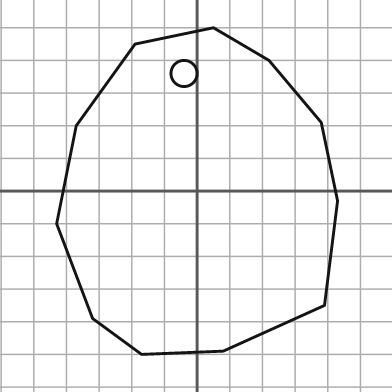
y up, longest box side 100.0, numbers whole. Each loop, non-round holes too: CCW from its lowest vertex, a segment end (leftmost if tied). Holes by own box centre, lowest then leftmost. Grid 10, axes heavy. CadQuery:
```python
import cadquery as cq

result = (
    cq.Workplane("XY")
    .moveTo(-17.0, -50.0)
    .lineTo(8.0, -49.0)
    .lineTo(39.0, -35.0)
    .lineTo(43.0, -3.0)
    .lineTo(38.0, 21.0)
    .lineTo(22.0, 40.0)
    .lineTo(5.0, 50.0)
    .lineTo(-19.0, 45.0)
    .lineTo(-37.0, 20.0)
    .lineTo(-43.0, -10.0)
    .lineTo(-32.0, -39.0)
    .close()
    .moveTo(-4.0, 36.0)
    .circle(4.0)
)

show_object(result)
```